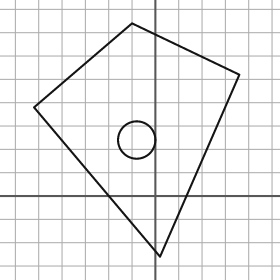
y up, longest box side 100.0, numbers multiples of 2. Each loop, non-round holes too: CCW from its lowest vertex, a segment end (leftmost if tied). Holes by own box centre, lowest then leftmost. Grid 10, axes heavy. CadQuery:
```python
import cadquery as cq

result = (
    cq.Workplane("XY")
    .moveTo(2.0, -26.0)
    .lineTo(36.0, 52.0)
    .lineTo(-10.0, 74.0)
    .lineTo(-52.0, 38.0)
    .close()
    .moveTo(-8.0, 24.0)
    .circle(8.0)
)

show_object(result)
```